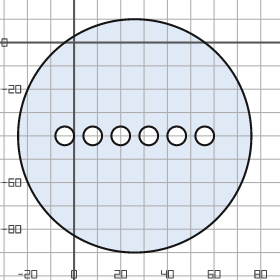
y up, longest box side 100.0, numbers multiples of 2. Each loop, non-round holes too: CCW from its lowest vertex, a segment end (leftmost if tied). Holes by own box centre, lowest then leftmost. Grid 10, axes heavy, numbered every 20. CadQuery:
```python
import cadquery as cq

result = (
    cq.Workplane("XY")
    .moveTo(26.0, -40.0)
    .circle(50.0)
    .moveTo(-4.0, -40.0)
    .circle(4.0)
    .moveTo(8.0, -40.0)
    .circle(4.0)
    .moveTo(20.0, -40.0)
    .circle(4.0)
    .moveTo(32.0, -40.0)
    .circle(4.0)
    .moveTo(44.0, -40.0)
    .circle(4.0)
    .moveTo(56.0, -40.0)
    .circle(4.0)
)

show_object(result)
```